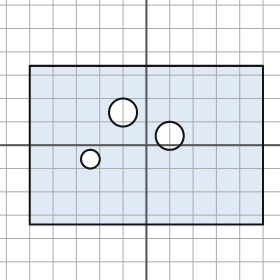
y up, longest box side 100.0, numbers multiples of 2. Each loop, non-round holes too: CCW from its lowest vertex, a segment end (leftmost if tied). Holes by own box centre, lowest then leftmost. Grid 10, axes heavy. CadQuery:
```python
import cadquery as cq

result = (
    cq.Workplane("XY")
    .moveTo(-50.0, -34.0)
    .lineTo(50.0, -34.0)
    .lineTo(50.0, 34.0)
    .lineTo(-50.0, 34.0)
    .close()
    .moveTo(-24.0, -6.0)
    .circle(4.0)
    .moveTo(10.0, 4.0)
    .circle(6.0)
    .moveTo(-10.0, 14.0)
    .circle(6.0)
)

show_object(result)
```